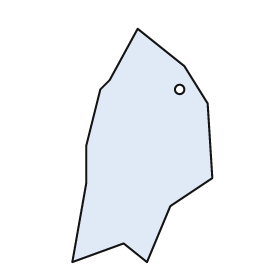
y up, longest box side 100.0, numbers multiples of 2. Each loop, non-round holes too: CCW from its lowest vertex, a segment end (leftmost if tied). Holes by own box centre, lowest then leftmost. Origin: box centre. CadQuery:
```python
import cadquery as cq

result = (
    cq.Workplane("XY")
    .moveTo(-30.0, -50.0)
    .lineTo(-8.0, -42.0)
    .lineTo(2.0, -50.0)
    .lineTo(12.0, -26.0)
    .lineTo(30.0, -14.0)
    .lineTo(28.0, 18.0)
    .lineTo(18.0, 34.0)
    .lineTo(-2.0, 50.0)
    .lineTo(-14.0, 28.0)
    .lineTo(-18.0, 24.0)
    .lineTo(-24.0, 0.0)
    .lineTo(-24.0, -16.0)
    .close()
    .moveTo(16.0, 24.0)
    .circle(2.0)
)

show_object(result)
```